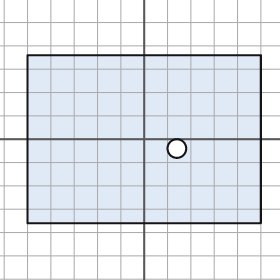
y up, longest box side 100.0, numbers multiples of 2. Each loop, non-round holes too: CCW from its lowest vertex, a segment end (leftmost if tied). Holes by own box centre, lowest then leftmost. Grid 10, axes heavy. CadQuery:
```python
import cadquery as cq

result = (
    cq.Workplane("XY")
    .moveTo(-50.0, -36.0)
    .lineTo(50.0, -36.0)
    .lineTo(50.0, 36.0)
    .lineTo(-50.0, 36.0)
    .close()
    .moveTo(14.0, -4.0)
    .circle(4.0)
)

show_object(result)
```